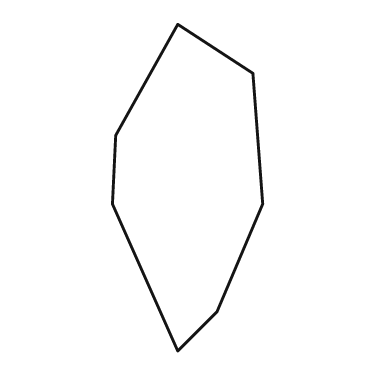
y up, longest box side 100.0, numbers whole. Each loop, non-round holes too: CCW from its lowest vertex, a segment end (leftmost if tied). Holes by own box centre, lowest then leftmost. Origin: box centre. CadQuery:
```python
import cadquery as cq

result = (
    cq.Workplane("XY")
    .moveTo(-3.0, -50.0)
    .lineTo(9.0, -38.0)
    .lineTo(23.0, -5.0)
    .lineTo(20.0, 35.0)
    .lineTo(-3.0, 50.0)
    .lineTo(-22.0, 16.0)
    .lineTo(-23.0, -5.0)
    .close()
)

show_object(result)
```